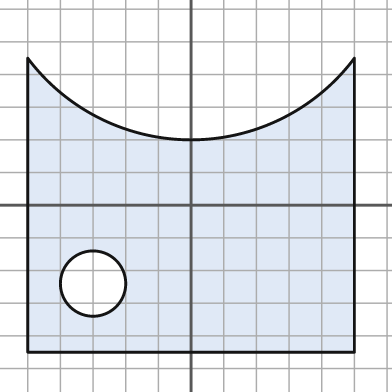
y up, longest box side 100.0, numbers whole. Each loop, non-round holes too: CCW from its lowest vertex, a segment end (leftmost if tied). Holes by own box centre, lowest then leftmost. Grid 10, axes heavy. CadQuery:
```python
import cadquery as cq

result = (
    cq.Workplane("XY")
    .moveTo(-50.0, -45.0)
    .lineTo(50.0, -45.0)
    .lineTo(50.0, 45.0)
    .threePointArc((0.0, 20.0), (-50.0, 45.0))
    .close()
    .moveTo(-30.0, -24.0)
    .circle(10.0)
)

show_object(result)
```